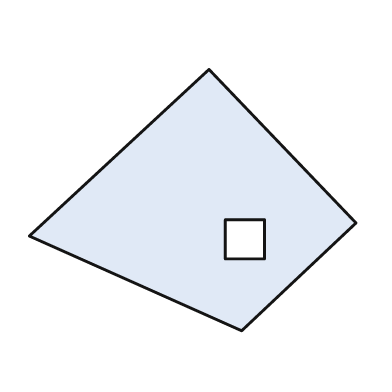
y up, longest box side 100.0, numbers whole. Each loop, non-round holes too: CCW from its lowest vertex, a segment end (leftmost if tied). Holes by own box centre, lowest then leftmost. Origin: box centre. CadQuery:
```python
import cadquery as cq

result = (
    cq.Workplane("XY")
    .moveTo(15.0, -40.0)
    .lineTo(50.0, -7.0)
    .lineTo(5.0, 40.0)
    .lineTo(-50.0, -11.0)
    .close()
    .moveTo(10.0, -18.0)
    .lineTo(22.0, -18.0)
    .lineTo(22.0, -6.0)
    .lineTo(10.0, -6.0)
    .close()
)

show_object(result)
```